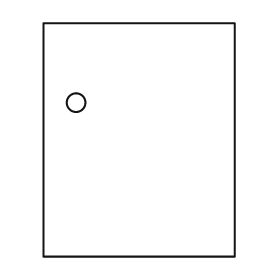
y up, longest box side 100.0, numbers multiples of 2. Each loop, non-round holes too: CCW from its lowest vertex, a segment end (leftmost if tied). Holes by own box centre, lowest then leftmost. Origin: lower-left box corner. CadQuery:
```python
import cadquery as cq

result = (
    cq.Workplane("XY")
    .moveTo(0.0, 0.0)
    .lineTo(82.0, 0.0)
    .lineTo(82.0, 100.0)
    .lineTo(0.0, 100.0)
    .close()
    .moveTo(14.0, 66.0)
    .circle(4.0)
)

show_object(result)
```